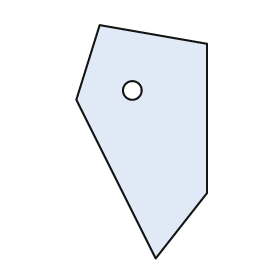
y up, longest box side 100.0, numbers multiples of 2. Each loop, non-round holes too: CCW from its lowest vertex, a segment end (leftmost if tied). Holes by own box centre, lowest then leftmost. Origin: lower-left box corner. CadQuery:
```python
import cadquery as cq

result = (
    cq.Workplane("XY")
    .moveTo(34.0, 0.0)
    .lineTo(56.0, 28.0)
    .lineTo(56.0, 92.0)
    .lineTo(10.0, 100.0)
    .lineTo(0.0, 68.0)
    .close()
    .moveTo(24.0, 72.0)
    .circle(4.0)
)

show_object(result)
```